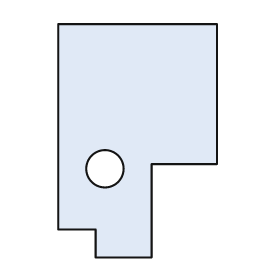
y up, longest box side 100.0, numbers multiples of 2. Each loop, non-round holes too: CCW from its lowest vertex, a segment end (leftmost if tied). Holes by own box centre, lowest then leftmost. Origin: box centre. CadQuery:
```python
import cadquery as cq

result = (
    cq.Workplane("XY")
    .moveTo(-18.0, -50.0)
    .lineTo(6.0, -50.0)
    .lineTo(6.0, -10.0)
    .lineTo(34.0, -10.0)
    .lineTo(34.0, 50.0)
    .lineTo(-34.0, 50.0)
    .lineTo(-34.0, -38.0)
    .lineTo(-18.0, -38.0)
    .close()
    .moveTo(-14.0, -12.0)
    .circle(8.0)
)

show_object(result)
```